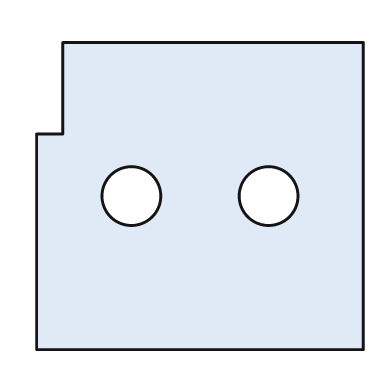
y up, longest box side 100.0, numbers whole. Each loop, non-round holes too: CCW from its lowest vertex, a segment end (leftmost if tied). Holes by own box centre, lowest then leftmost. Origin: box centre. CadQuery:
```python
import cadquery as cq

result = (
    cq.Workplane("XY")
    .moveTo(-50.0, -47.0)
    .lineTo(50.0, -47.0)
    .lineTo(50.0, 47.0)
    .lineTo(-42.0, 47.0)
    .lineTo(-42.0, 19.0)
    .lineTo(-50.0, 19.0)
    .close()
    .moveTo(-21.0, 0.0)
    .circle(9.0)
    .moveTo(21.0, 0.0)
    .circle(9.0)
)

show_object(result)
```